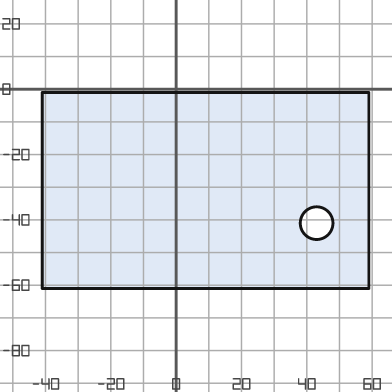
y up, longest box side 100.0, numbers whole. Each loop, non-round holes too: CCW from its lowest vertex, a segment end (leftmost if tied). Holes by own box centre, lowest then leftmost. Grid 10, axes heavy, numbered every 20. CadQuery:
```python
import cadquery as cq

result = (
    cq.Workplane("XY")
    .moveTo(-41.0, -61.0)
    .lineTo(59.0, -61.0)
    .lineTo(59.0, -1.0)
    .lineTo(-41.0, -1.0)
    .close()
    .moveTo(43.0, -41.0)
    .circle(5.0)
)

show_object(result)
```